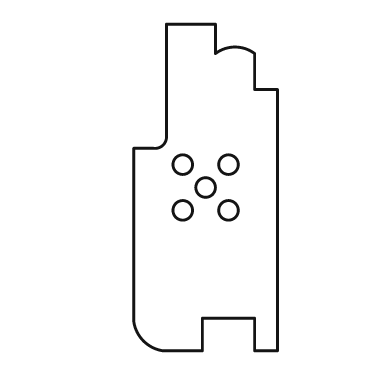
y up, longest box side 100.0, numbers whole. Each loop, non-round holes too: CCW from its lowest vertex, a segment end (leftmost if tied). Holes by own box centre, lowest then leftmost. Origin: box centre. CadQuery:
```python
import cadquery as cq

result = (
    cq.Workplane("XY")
    .moveTo(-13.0, -50.0)
    .lineTo(-1.0, -50.0)
    .lineTo(-1.0, -40.0)
    .lineTo(15.0, -40.0)
    .lineTo(15.0, -50.0)
    .lineTo(22.0, -50.0)
    .lineTo(22.0, 30.0)
    .lineTo(15.0, 30.0)
    .lineTo(15.0, 41.0)
    .threePointArc((9.0, 43.0), (3.0, 41.0))
    .lineTo(3.0, 50.0)
    .lineTo(-12.0, 50.0)
    .lineTo(-12.0, 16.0)
    .threePointArc((-13.0, 13.0), (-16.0, 12.0))
    .lineTo(-22.0, 12.0)
    .lineTo(-22.0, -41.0)
    .threePointArc((-19.0, -47.0), (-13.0, -50.0))
    .close()
    .moveTo(-7.0, -7.0)
    .circle(3.0)
    .moveTo(7.0, -7.0)
    .circle(3.0)
    .moveTo(0.0, 0.0)
    .circle(3.0)
    .moveTo(-7.0, 7.0)
    .circle(3.0)
    .moveTo(7.0, 7.0)
    .circle(3.0)
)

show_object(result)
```